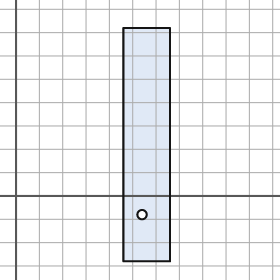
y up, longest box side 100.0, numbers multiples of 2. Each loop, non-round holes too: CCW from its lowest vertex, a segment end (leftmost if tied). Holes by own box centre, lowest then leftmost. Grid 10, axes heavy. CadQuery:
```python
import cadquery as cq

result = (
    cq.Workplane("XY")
    .moveTo(46.0, -28.0)
    .lineTo(66.0, -28.0)
    .lineTo(66.0, 72.0)
    .lineTo(46.0, 72.0)
    .close()
    .moveTo(54.0, -8.0)
    .circle(2.0)
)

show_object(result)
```